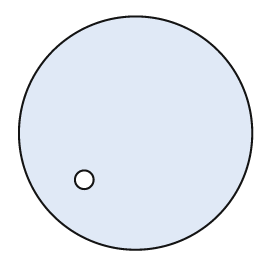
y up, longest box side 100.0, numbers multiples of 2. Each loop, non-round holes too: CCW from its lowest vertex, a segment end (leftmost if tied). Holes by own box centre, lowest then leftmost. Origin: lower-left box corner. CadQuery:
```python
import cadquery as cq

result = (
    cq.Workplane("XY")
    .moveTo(50.0, 50.0)
    .circle(50.0)
    .moveTo(28.0, 30.0)
    .circle(4.0)
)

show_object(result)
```